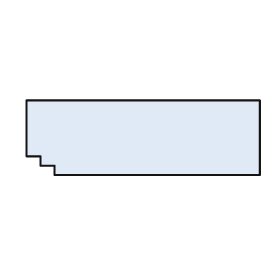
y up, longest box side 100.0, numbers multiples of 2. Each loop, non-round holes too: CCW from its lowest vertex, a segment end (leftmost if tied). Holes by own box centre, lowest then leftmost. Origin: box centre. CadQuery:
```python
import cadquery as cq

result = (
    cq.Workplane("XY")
    .moveTo(-38.0, -16.0)
    .lineTo(50.0, -16.0)
    .lineTo(50.0, 16.0)
    .lineTo(-50.0, 16.0)
    .lineTo(-50.0, -8.0)
    .lineTo(-44.0, -8.0)
    .lineTo(-44.0, -12.0)
    .lineTo(-38.0, -12.0)
    .close()
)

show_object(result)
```